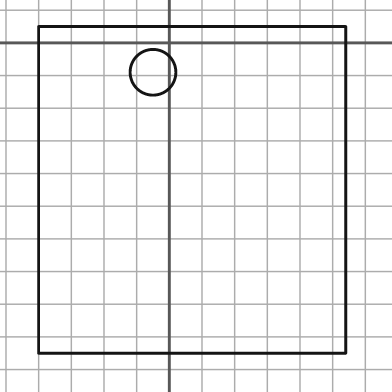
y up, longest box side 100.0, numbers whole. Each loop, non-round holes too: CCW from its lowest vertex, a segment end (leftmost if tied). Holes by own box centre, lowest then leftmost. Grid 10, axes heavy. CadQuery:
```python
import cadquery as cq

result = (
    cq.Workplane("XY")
    .moveTo(-40.0, -95.0)
    .lineTo(54.0, -95.0)
    .lineTo(54.0, 5.0)
    .lineTo(-40.0, 5.0)
    .close()
    .moveTo(-5.0, -9.0)
    .circle(7.0)
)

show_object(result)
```